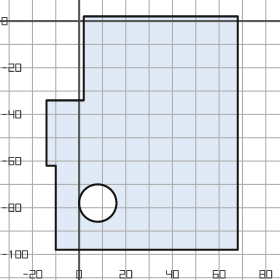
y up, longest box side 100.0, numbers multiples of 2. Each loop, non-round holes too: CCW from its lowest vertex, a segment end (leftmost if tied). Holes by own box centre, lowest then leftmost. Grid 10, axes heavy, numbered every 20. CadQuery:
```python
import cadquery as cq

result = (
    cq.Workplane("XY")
    .moveTo(-10.0, -98.0)
    .lineTo(68.0, -98.0)
    .lineTo(68.0, 2.0)
    .lineTo(2.0, 2.0)
    .lineTo(2.0, -34.0)
    .lineTo(-14.0, -34.0)
    .lineTo(-14.0, -62.0)
    .lineTo(-10.0, -62.0)
    .close()
    .moveTo(8.0, -78.0)
    .circle(8.0)
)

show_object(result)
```